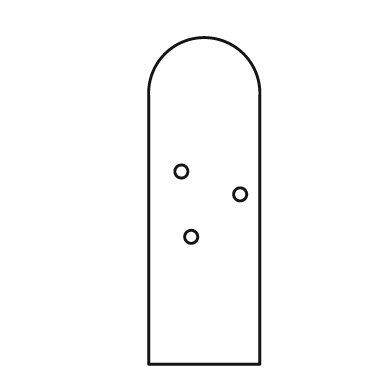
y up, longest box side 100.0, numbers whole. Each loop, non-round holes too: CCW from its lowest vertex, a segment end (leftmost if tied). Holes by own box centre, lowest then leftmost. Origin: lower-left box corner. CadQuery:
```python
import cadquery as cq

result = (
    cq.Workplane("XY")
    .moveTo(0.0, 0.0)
    .lineTo(34.0, 0.0)
    .lineTo(34.0, 82.0)
    .threePointArc((17.0, 100.0), (0.0, 82.0))
    .close()
    .moveTo(13.0, 39.0)
    .circle(2.0)
    .moveTo(28.0, 52.0)
    .circle(2.0)
    .moveTo(10.0, 59.0)
    .circle(2.0)
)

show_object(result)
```